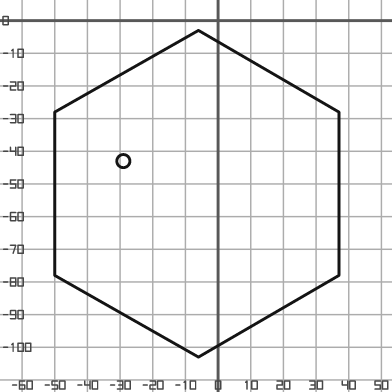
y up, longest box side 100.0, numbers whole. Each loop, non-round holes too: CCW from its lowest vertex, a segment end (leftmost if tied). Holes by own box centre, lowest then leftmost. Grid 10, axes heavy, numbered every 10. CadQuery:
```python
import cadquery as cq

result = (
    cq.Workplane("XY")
    .moveTo(-6.0, -103.0)
    .lineTo(37.0, -78.0)
    .lineTo(37.0, -28.0)
    .lineTo(-6.0, -3.0)
    .lineTo(-50.0, -28.0)
    .lineTo(-50.0, -78.0)
    .close()
    .moveTo(-29.0, -43.0)
    .circle(2.0)
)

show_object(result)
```